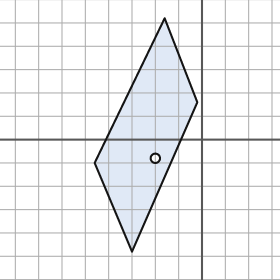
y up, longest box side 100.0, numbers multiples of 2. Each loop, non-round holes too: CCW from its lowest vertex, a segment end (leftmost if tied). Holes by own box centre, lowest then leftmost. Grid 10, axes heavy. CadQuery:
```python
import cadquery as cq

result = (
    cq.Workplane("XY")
    .moveTo(-30.0, -48.0)
    .lineTo(-2.0, 16.0)
    .lineTo(-16.0, 52.0)
    .lineTo(-46.0, -10.0)
    .close()
    .moveTo(-20.0, -8.0)
    .circle(2.0)
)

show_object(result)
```